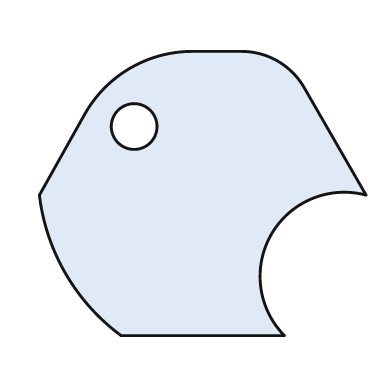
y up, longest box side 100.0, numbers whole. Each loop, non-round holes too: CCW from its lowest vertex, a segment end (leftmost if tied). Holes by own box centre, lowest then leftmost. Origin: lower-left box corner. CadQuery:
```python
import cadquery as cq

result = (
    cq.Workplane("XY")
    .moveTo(25.0, 0.0)
    .lineTo(75.0, 0.0)
    .threePointArc((71.0, 31.0), (100.0, 43.0))
    .lineTo(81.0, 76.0)
    .threePointArc((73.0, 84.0), (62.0, 87.0))
    .lineTo(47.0, 87.0)
    .threePointArc((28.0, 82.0), (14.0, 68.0))
    .lineTo(0.0, 43.0)
    .threePointArc((8.0, 19.0), (25.0, 0.0))
    .close()
    .moveTo(29.0, 64.0)
    .circle(7.0)
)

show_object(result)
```